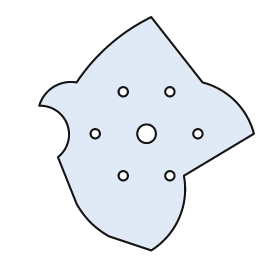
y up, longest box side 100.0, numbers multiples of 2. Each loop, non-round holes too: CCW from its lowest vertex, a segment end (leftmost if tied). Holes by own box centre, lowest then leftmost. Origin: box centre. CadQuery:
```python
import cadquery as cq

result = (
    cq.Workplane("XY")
    .moveTo(2.0, -50.0)
    .threePointArc((14.0, -36.0), (16.0, -18.0))
    .lineTo(46.0, 0.0)
    .threePointArc((38.0, 14.0), (24.0, 22.0))
    .lineTo(2.0, 50.0)
    .threePointArc((-16.0, 38.0), (-30.0, 22.0))
    .threePointArc((-40.0, 20.0), (-46.0, 12.0))
    .threePointArc((-34.0, 4.0), (-38.0, -10.0))
    .lineTo(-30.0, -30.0)
    .threePointArc((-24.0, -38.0), (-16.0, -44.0))
    .close()
    .moveTo(-10.0, -18.0)
    .circle(2.0)
    .moveTo(10.0, -18.0)
    .circle(2.0)
    .moveTo(-22.0, 0.0)
    .circle(2.0)
    .moveTo(0.0, 0.0)
    .circle(4.0)
    .moveTo(22.0, 0.0)
    .circle(2.0)
    .moveTo(-10.0, 18.0)
    .circle(2.0)
    .moveTo(10.0, 18.0)
    .circle(2.0)
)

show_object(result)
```